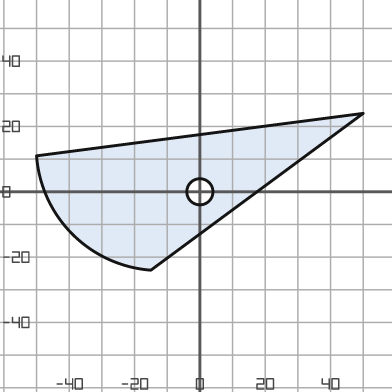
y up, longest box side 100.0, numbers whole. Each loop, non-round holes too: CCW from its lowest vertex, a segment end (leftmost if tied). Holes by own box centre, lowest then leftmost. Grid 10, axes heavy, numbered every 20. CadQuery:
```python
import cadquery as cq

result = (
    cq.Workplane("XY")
    .moveTo(-15.0, -24.0)
    .lineTo(50.0, 24.0)
    .lineTo(-50.0, 11.0)
    .threePointArc((-39.0, -13.0), (-15.0, -24.0))
    .close()
    .moveTo(0.0, 0.0)
    .circle(4.0)
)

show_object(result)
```